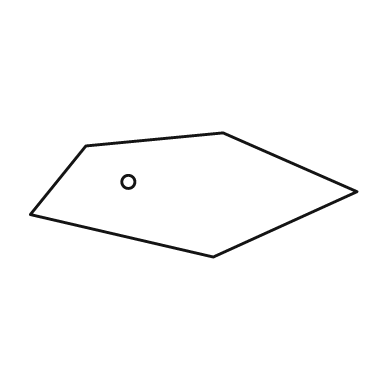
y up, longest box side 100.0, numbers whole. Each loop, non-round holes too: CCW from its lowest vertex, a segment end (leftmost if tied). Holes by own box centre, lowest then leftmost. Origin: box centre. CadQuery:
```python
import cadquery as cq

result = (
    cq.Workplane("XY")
    .moveTo(6.0, -19.0)
    .lineTo(50.0, 1.0)
    .lineTo(9.0, 19.0)
    .lineTo(-33.0, 15.0)
    .lineTo(-50.0, -6.0)
    .close()
    .moveTo(-20.0, 4.0)
    .circle(2.0)
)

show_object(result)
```